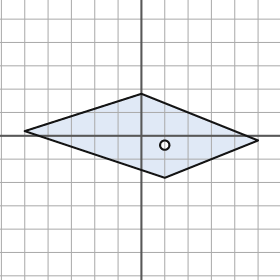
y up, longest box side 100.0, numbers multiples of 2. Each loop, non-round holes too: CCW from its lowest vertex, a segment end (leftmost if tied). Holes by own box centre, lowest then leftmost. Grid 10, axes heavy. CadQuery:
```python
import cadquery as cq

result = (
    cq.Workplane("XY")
    .moveTo(10.0, -18.0)
    .lineTo(50.0, -2.0)
    .lineTo(0.0, 18.0)
    .lineTo(-50.0, 2.0)
    .close()
    .moveTo(10.0, -4.0)
    .circle(2.0)
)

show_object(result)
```